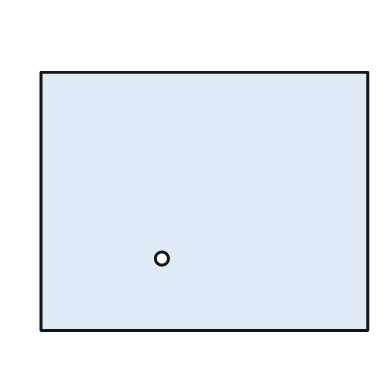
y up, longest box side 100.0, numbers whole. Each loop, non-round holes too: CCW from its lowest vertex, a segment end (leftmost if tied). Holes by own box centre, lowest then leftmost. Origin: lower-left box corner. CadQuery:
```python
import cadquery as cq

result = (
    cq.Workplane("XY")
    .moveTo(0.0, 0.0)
    .lineTo(100.0, 0.0)
    .lineTo(100.0, 79.0)
    .lineTo(0.0, 79.0)
    .close()
    .moveTo(37.0, 22.0)
    .circle(2.0)
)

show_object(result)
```